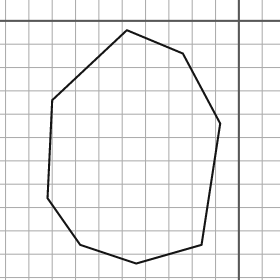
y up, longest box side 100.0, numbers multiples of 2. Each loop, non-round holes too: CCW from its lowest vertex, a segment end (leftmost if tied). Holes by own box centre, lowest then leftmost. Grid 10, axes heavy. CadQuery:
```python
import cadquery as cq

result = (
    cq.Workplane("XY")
    .moveTo(-44.0, -104.0)
    .lineTo(-16.0, -96.0)
    .lineTo(-8.0, -44.0)
    .lineTo(-24.0, -14.0)
    .lineTo(-48.0, -4.0)
    .lineTo(-80.0, -34.0)
    .lineTo(-82.0, -76.0)
    .lineTo(-68.0, -96.0)
    .close()
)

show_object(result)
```